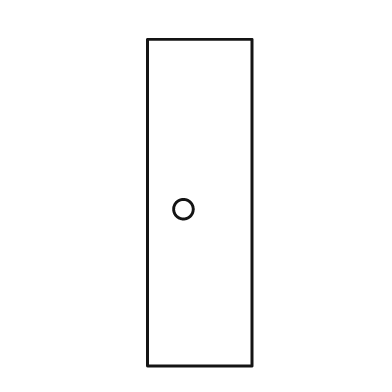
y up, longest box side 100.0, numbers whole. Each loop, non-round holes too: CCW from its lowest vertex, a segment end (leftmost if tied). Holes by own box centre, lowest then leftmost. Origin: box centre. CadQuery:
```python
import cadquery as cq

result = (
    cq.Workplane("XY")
    .moveTo(-16.0, -50.0)
    .lineTo(16.0, -50.0)
    .lineTo(16.0, 50.0)
    .lineTo(-16.0, 50.0)
    .close()
    .moveTo(-5.0, -2.0)
    .circle(3.0)
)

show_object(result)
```